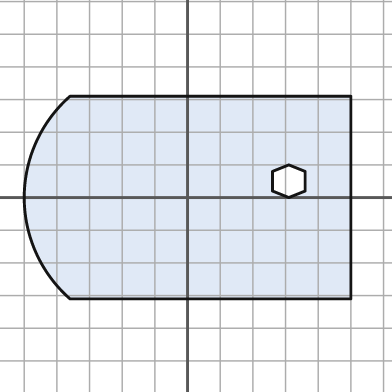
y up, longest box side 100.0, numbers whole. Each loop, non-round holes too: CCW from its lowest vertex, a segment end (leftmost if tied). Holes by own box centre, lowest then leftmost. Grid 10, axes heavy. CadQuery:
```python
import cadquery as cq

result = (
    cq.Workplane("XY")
    .moveTo(-36.0, -31.0)
    .lineTo(50.0, -31.0)
    .lineTo(50.0, 31.0)
    .lineTo(-36.0, 31.0)
    .threePointArc((-50.0, 0.0), (-36.0, -31.0))
    .close()
    .moveTo(31.0, 0.0)
    .lineTo(36.0, 2.0)
    .lineTo(36.0, 8.0)
    .lineTo(31.0, 10.0)
    .lineTo(26.0, 8.0)
    .lineTo(26.0, 2.0)
    .close()
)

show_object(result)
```